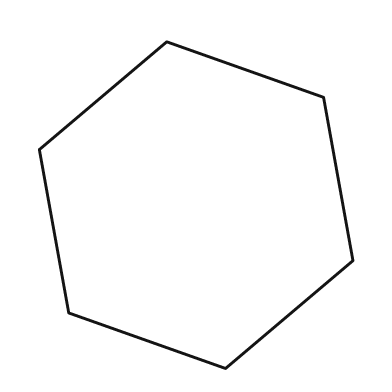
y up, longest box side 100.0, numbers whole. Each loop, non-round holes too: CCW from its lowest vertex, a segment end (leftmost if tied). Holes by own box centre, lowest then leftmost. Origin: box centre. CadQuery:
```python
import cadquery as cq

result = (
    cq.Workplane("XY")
    .moveTo(9.0, -50.0)
    .lineTo(48.0, -17.0)
    .lineTo(39.0, 33.0)
    .lineTo(-9.0, 50.0)
    .lineTo(-48.0, 17.0)
    .lineTo(-39.0, -33.0)
    .close()
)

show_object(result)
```